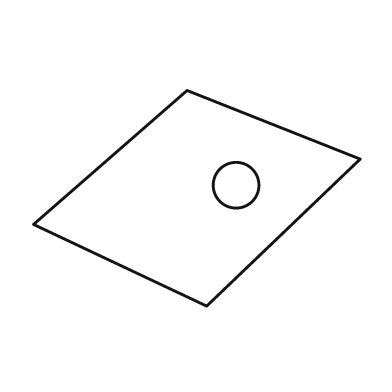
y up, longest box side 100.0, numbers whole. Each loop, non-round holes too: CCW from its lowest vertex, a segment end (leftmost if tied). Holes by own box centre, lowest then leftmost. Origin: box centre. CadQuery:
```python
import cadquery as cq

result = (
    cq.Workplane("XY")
    .moveTo(3.0, -33.0)
    .lineTo(50.0, 12.0)
    .lineTo(-3.0, 33.0)
    .lineTo(-50.0, -8.0)
    .close()
    .moveTo(12.0, 4.0)
    .circle(7.0)
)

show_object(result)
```